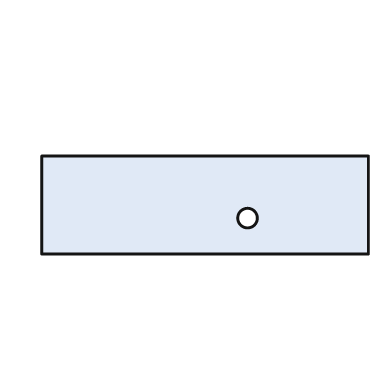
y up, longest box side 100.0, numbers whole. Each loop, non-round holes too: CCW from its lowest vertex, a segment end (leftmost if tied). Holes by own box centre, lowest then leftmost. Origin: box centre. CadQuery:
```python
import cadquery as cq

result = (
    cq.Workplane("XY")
    .moveTo(-50.0, -15.0)
    .lineTo(50.0, -15.0)
    .lineTo(50.0, 15.0)
    .lineTo(-50.0, 15.0)
    .close()
    .moveTo(13.0, -4.0)
    .circle(3.0)
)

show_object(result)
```